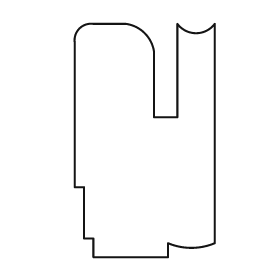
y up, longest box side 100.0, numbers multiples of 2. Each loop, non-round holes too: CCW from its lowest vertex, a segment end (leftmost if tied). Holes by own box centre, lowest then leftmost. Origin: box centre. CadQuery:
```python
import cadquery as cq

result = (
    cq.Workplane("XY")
    .moveTo(-22.0, -50.0)
    .lineTo(10.0, -50.0)
    .lineTo(10.0, -44.0)
    .threePointArc((20.0, -46.0), (30.0, -44.0))
    .lineTo(30.0, 50.0)
    .threePointArc((22.0, 46.0), (14.0, 50.0))
    .lineTo(14.0, 10.0)
    .lineTo(4.0, 10.0)
    .lineTo(4.0, 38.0)
    .threePointArc((0.0, 46.0), (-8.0, 50.0))
    .lineTo(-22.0, 50.0)
    .threePointArc((-28.0, 48.0), (-30.0, 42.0))
    .lineTo(-30.0, -20.0)
    .lineTo(-26.0, -20.0)
    .lineTo(-26.0, -42.0)
    .lineTo(-22.0, -42.0)
    .close()
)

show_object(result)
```